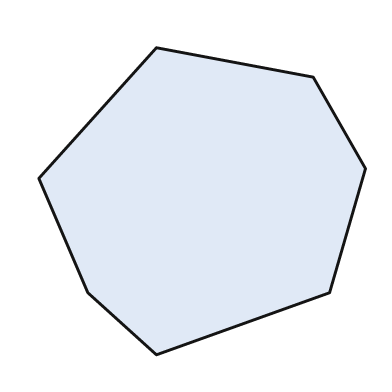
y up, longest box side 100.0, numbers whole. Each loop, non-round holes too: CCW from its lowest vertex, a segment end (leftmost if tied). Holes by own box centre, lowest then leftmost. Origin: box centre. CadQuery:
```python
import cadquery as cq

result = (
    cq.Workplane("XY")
    .moveTo(-14.0, -47.0)
    .lineTo(39.0, -28.0)
    .lineTo(50.0, 10.0)
    .lineTo(34.0, 38.0)
    .lineTo(-14.0, 47.0)
    .lineTo(-50.0, 7.0)
    .lineTo(-35.0, -28.0)
    .close()
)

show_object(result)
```